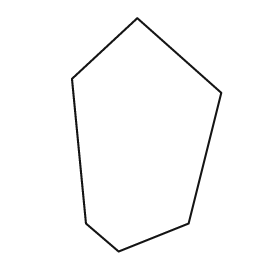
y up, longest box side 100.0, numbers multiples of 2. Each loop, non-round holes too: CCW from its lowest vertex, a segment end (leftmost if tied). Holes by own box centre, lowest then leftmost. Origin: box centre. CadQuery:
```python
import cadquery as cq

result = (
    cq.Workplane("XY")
    .moveTo(-12.0, -50.0)
    .lineTo(18.0, -38.0)
    .lineTo(32.0, 18.0)
    .lineTo(-4.0, 50.0)
    .lineTo(-32.0, 24.0)
    .lineTo(-26.0, -38.0)
    .close()
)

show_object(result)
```